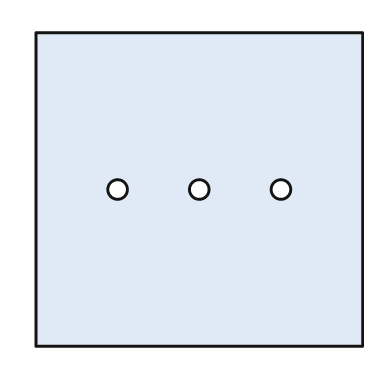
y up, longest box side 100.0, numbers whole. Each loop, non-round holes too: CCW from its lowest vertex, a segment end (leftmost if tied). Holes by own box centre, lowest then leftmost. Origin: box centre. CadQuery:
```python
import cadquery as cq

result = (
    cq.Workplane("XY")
    .moveTo(-50.0, -48.0)
    .lineTo(50.0, -48.0)
    .lineTo(50.0, 48.0)
    .lineTo(-50.0, 48.0)
    .close()
    .moveTo(-25.0, 0.0)
    .circle(3.0)
    .moveTo(0.0, 0.0)
    .circle(3.0)
    .moveTo(25.0, 0.0)
    .circle(3.0)
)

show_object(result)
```